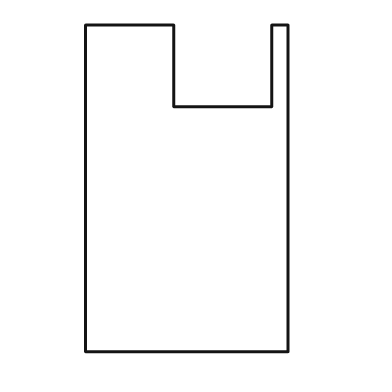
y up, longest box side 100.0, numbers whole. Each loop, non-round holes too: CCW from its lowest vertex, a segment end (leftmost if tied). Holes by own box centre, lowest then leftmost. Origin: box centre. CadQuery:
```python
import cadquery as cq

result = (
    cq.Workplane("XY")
    .moveTo(-31.0, -50.0)
    .lineTo(31.0, -50.0)
    .lineTo(31.0, 50.0)
    .lineTo(26.0, 50.0)
    .lineTo(26.0, 25.0)
    .lineTo(-4.0, 25.0)
    .lineTo(-4.0, 50.0)
    .lineTo(-31.0, 50.0)
    .close()
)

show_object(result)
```